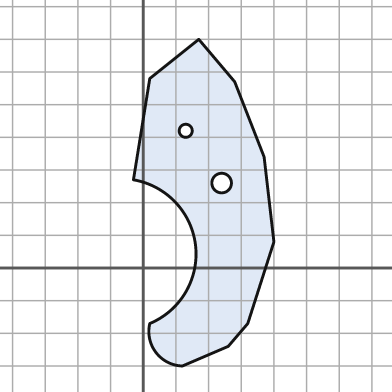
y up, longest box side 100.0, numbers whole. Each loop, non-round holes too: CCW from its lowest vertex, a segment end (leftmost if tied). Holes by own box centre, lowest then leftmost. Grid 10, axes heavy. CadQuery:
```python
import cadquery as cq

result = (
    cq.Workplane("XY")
    .moveTo(12.0, -30.0)
    .lineTo(26.0, -24.0)
    .lineTo(32.0, -17.0)
    .lineTo(40.0, 8.0)
    .lineTo(37.0, 34.0)
    .lineTo(28.0, 57.0)
    .lineTo(17.0, 70.0)
    .lineTo(2.0, 58.0)
    .lineTo(-3.0, 27.0)
    .threePointArc((16.0, 7.0), (2.0, -17.0))
    .threePointArc((4.0, -26.0), (12.0, -30.0))
    .close()
    .moveTo(24.0, 26.0)
    .circle(3.0)
    .moveTo(13.0, 42.0)
    .circle(2.0)
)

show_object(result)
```